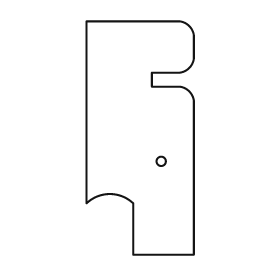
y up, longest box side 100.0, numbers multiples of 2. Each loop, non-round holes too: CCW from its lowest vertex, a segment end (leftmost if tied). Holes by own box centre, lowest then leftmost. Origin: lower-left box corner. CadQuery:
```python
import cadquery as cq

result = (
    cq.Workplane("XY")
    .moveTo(20.0, 0.0)
    .lineTo(46.0, 0.0)
    .lineTo(46.0, 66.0)
    .threePointArc((44.0, 70.0), (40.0, 72.0))
    .lineTo(28.0, 72.0)
    .lineTo(28.0, 78.0)
    .lineTo(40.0, 78.0)
    .threePointArc((44.0, 80.0), (46.0, 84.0))
    .lineTo(46.0, 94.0)
    .threePointArc((44.0, 98.0), (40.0, 100.0))
    .lineTo(0.0, 100.0)
    .lineTo(0.0, 22.0)
    .threePointArc((10.0, 26.0), (20.0, 22.0))
    .close()
    .moveTo(32.0, 40.0)
    .circle(2.0)
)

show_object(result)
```